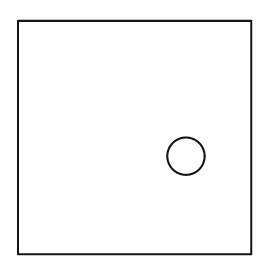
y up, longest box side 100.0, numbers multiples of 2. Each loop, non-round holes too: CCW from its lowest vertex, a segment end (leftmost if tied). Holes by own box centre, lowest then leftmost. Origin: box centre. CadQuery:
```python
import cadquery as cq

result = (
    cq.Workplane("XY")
    .moveTo(-50.0, -50.0)
    .lineTo(50.0, -50.0)
    .lineTo(50.0, 50.0)
    .lineTo(-50.0, 50.0)
    .close()
    .moveTo(22.0, -8.0)
    .circle(8.0)
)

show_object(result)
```